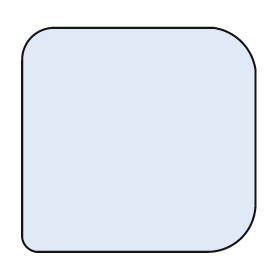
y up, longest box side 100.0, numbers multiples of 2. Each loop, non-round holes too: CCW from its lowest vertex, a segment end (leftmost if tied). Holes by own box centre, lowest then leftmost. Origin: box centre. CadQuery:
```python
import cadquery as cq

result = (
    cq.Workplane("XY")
    .moveTo(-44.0, -48.0)
    .lineTo(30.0, -48.0)
    .threePointArc((44.0, -42.0), (50.0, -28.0))
    .lineTo(50.0, 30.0)
    .threePointArc((44.0, 42.0), (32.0, 48.0))
    .lineTo(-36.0, 48.0)
    .threePointArc((-46.0, 44.0), (-50.0, 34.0))
    .lineTo(-50.0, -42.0)
    .threePointArc((-48.0, -46.0), (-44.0, -48.0))
    .close()
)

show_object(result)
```